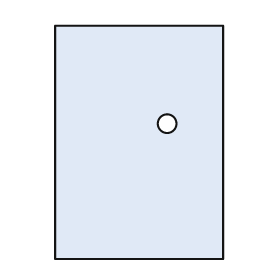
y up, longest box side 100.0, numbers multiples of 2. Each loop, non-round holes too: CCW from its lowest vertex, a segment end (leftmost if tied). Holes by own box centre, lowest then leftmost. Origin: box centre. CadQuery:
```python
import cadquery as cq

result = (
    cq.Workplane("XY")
    .moveTo(-36.0, -50.0)
    .lineTo(36.0, -50.0)
    .lineTo(36.0, 50.0)
    .lineTo(-36.0, 50.0)
    .close()
    .moveTo(12.0, 8.0)
    .circle(4.0)
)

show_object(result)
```